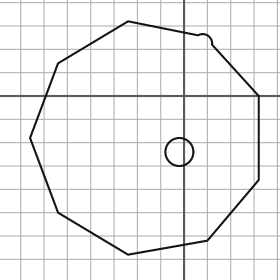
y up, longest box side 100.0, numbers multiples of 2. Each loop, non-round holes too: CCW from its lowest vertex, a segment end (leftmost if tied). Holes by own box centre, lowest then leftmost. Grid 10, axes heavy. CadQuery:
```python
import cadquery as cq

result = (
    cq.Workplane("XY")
    .moveTo(-24.0, -68.0)
    .lineTo(10.0, -62.0)
    .lineTo(32.0, -36.0)
    .lineTo(32.0, 0.0)
    .lineTo(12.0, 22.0)
    .threePointArc((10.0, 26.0), (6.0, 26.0))
    .lineTo(-24.0, 32.0)
    .lineTo(-54.0, 14.0)
    .lineTo(-66.0, -18.0)
    .lineTo(-54.0, -50.0)
    .close()
    .moveTo(-2.0, -24.0)
    .circle(6.0)
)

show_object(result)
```